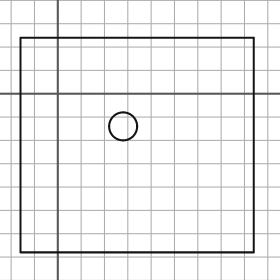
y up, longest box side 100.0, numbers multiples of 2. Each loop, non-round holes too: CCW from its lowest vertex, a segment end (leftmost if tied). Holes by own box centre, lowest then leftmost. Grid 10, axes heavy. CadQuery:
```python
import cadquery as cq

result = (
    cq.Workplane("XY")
    .moveTo(-16.0, -68.0)
    .lineTo(84.0, -68.0)
    .lineTo(84.0, 24.0)
    .lineTo(-16.0, 24.0)
    .close()
    .moveTo(28.0, -14.0)
    .circle(6.0)
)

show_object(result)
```